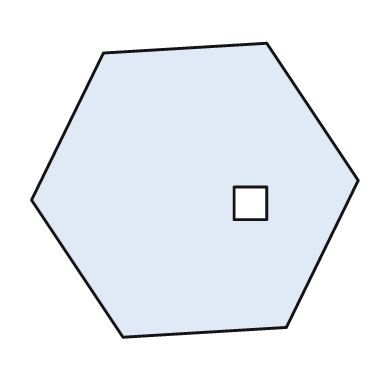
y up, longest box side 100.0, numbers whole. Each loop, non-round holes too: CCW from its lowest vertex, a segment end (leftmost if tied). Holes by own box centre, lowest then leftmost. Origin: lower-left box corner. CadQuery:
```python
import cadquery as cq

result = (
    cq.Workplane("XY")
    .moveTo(28.0, 0.0)
    .lineTo(78.0, 3.0)
    .lineTo(100.0, 48.0)
    .lineTo(72.0, 90.0)
    .lineTo(22.0, 87.0)
    .lineTo(0.0, 42.0)
    .close()
    .moveTo(62.0, 36.0)
    .lineTo(72.0, 36.0)
    .lineTo(72.0, 46.0)
    .lineTo(62.0, 46.0)
    .close()
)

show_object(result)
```